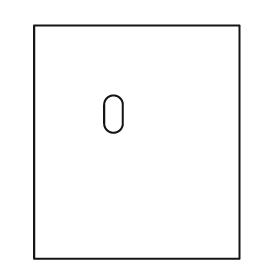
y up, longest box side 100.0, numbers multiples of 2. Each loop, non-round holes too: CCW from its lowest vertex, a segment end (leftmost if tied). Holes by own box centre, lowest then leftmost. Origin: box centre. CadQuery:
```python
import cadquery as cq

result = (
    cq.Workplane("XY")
    .moveTo(-44.0, -50.0)
    .lineTo(44.0, -50.0)
    .lineTo(44.0, 50.0)
    .lineTo(-44.0, 50.0)
    .close()
    .moveTo(-14.0, 8.0)
    .threePointArc((-10.0, 4.0), (-6.0, 8.0))
    .lineTo(-6.0, 16.0)
    .threePointArc((-10.0, 20.0), (-14.0, 16.0))
    .close()
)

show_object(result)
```